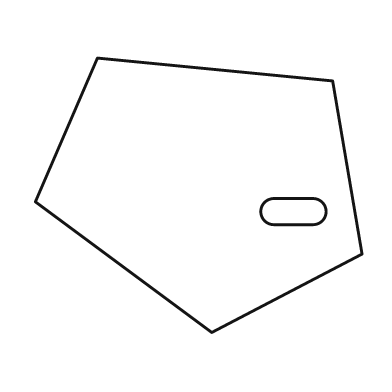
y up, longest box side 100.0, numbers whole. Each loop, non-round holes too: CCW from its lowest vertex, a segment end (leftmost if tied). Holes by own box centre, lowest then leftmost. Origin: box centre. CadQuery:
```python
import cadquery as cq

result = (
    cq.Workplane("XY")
    .moveTo(4.0, -42.0)
    .lineTo(50.0, -18.0)
    .lineTo(41.0, 35.0)
    .lineTo(-31.0, 42.0)
    .lineTo(-50.0, -2.0)
    .close()
    .moveTo(23.0, -9.0)
    .lineTo(35.0, -9.0)
    .threePointArc((39.0, -5.0), (35.0, -1.0))
    .lineTo(23.0, -1.0)
    .threePointArc((19.0, -5.0), (23.0, -9.0))
    .close()
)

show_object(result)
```